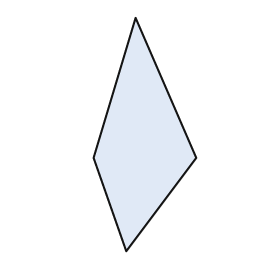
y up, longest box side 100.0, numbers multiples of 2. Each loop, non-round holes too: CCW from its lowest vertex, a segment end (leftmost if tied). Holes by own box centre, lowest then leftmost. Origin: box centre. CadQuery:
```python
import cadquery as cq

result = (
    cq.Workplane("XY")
    .moveTo(-8.0, -50.0)
    .lineTo(22.0, -10.0)
    .lineTo(-4.0, 50.0)
    .lineTo(-22.0, -10.0)
    .close()
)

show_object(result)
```